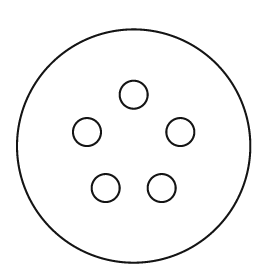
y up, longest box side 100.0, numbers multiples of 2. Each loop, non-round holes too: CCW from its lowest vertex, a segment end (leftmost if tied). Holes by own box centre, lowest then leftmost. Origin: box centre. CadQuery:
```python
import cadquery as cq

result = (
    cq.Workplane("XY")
    .moveTo(0.0, 0.0)
    .circle(50.0)
    .moveTo(-12.0, -18.0)
    .circle(6.0)
    .moveTo(12.0, -18.0)
    .circle(6.0)
    .moveTo(-20.0, 6.0)
    .circle(6.0)
    .moveTo(20.0, 6.0)
    .circle(6.0)
    .moveTo(0.0, 22.0)
    .circle(6.0)
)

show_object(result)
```